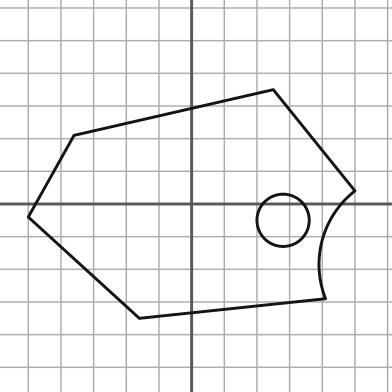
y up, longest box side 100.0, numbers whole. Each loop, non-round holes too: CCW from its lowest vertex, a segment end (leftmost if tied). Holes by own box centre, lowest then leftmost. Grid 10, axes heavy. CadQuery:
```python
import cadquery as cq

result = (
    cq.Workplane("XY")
    .moveTo(-16.0, -35.0)
    .lineTo(41.0, -29.0)
    .threePointArc((40.0, -11.0), (50.0, 4.0))
    .lineTo(25.0, 35.0)
    .lineTo(-36.0, 21.0)
    .lineTo(-50.0, -4.0)
    .close()
    .moveTo(28.0, -5.0)
    .circle(8.0)
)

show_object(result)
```